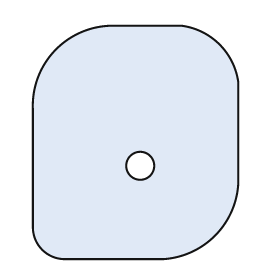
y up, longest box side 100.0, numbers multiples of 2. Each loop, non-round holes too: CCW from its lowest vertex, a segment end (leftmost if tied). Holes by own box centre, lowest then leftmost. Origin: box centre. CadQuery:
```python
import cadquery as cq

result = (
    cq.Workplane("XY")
    .moveTo(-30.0, -50.0)
    .lineTo(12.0, -50.0)
    .threePointArc((34.0, -40.0), (44.0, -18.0))
    .lineTo(44.0, 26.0)
    .threePointArc((36.0, 42.0), (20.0, 50.0))
    .lineTo(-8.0, 50.0)
    .threePointArc((-34.0, 40.0), (-44.0, 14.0))
    .lineTo(-44.0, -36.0)
    .threePointArc((-40.0, -46.0), (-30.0, -50.0))
    .close()
    .moveTo(2.0, -10.0)
    .circle(6.0)
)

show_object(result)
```